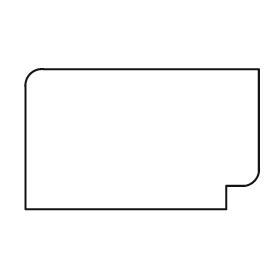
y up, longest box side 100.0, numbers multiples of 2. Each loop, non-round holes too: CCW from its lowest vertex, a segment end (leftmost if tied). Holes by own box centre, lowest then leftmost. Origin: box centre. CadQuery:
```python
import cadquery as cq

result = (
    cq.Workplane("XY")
    .moveTo(-50.0, -30.0)
    .lineTo(36.0, -30.0)
    .lineTo(36.0, -20.0)
    .lineTo(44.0, -20.0)
    .threePointArc((48.0, -18.0), (50.0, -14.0))
    .lineTo(50.0, 30.0)
    .lineTo(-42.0, 30.0)
    .threePointArc((-48.0, 28.0), (-50.0, 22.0))
    .close()
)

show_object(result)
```